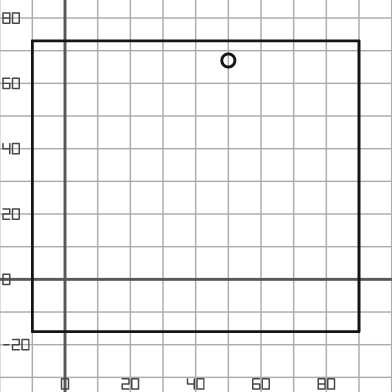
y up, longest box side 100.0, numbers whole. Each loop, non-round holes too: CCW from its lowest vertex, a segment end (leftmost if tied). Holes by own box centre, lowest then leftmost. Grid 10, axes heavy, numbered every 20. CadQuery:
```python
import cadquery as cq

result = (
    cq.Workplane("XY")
    .moveTo(-10.0, -16.0)
    .lineTo(90.0, -16.0)
    .lineTo(90.0, 73.0)
    .lineTo(-10.0, 73.0)
    .close()
    .moveTo(50.0, 67.0)
    .circle(2.0)
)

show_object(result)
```